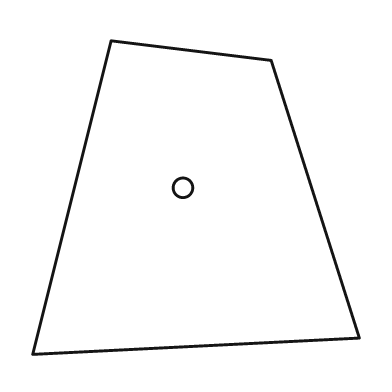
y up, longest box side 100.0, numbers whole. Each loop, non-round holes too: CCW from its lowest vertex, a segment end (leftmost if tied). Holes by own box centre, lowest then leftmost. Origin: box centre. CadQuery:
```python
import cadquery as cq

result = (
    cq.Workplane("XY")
    .moveTo(-50.0, -48.0)
    .lineTo(50.0, -43.0)
    .lineTo(23.0, 42.0)
    .lineTo(-26.0, 48.0)
    .close()
    .moveTo(-4.0, 3.0)
    .circle(3.0)
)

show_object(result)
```